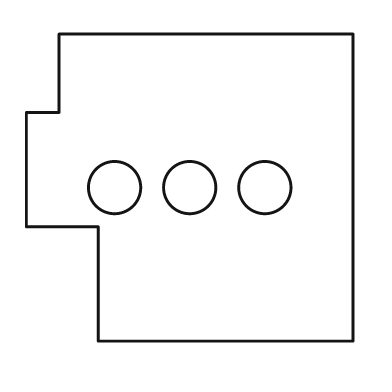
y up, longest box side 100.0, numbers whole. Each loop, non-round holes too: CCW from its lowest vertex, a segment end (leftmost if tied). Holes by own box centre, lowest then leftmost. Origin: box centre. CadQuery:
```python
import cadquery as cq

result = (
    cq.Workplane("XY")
    .moveTo(-28.0, -47.0)
    .lineTo(50.0, -47.0)
    .lineTo(50.0, 47.0)
    .lineTo(-40.0, 47.0)
    .lineTo(-40.0, 23.0)
    .lineTo(-50.0, 23.0)
    .lineTo(-50.0, -12.0)
    .lineTo(-28.0, -12.0)
    .close()
    .moveTo(-23.0, 0.0)
    .circle(8.0)
    .moveTo(0.0, 0.0)
    .circle(8.0)
    .moveTo(23.0, 0.0)
    .circle(8.0)
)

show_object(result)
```